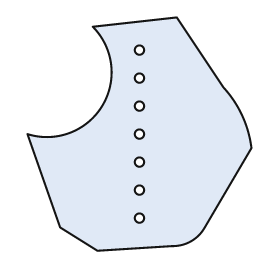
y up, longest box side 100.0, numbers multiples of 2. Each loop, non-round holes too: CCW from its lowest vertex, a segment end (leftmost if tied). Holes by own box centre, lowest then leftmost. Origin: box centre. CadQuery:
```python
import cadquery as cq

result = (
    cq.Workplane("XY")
    .moveTo(-18.0, -50.0)
    .lineTo(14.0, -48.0)
    .threePointArc((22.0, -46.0), (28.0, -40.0))
    .lineTo(48.0, -6.0)
    .threePointArc((44.0, 8.0), (36.0, 20.0))
    .lineTo(16.0, 50.0)
    .lineTo(-20.0, 46.0)
    .threePointArc((-16.0, 12.0), (-48.0, 0.0))
    .lineTo(-34.0, -40.0)
    .close()
    .moveTo(0.0, -36.0)
    .circle(2.0)
    .moveTo(0.0, -24.0)
    .circle(2.0)
    .moveTo(0.0, -12.0)
    .circle(2.0)
    .moveTo(0.0, 0.0)
    .circle(2.0)
    .moveTo(0.0, 12.0)
    .circle(2.0)
    .moveTo(0.0, 24.0)
    .circle(2.0)
    .moveTo(0.0, 36.0)
    .circle(2.0)
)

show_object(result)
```